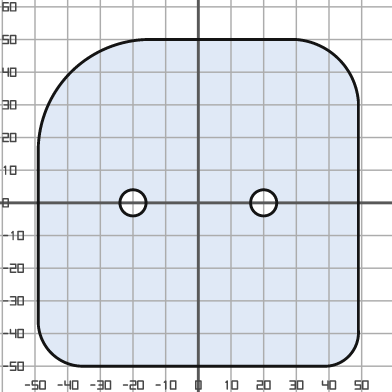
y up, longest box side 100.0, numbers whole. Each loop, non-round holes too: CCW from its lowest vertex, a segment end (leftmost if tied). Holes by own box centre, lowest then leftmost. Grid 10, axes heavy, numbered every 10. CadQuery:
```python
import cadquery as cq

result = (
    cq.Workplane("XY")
    .moveTo(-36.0, -50.0)
    .lineTo(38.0, -50.0)
    .threePointArc((46.0, -47.0), (49.0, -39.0))
    .lineTo(49.0, 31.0)
    .threePointArc((43.0, 44.0), (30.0, 50.0))
    .lineTo(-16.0, 50.0)
    .threePointArc((-39.0, 40.0), (-49.0, 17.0))
    .lineTo(-49.0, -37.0)
    .threePointArc((-45.0, -46.0), (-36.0, -50.0))
    .close()
    .moveTo(-20.0, 0.0)
    .circle(4.0)
    .moveTo(20.0, 0.0)
    .circle(4.0)
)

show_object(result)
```